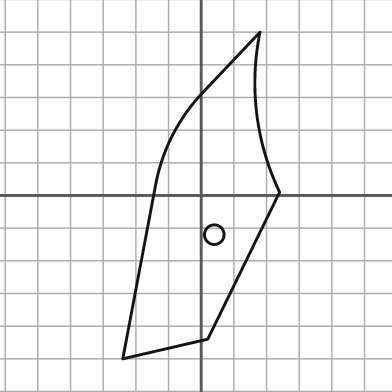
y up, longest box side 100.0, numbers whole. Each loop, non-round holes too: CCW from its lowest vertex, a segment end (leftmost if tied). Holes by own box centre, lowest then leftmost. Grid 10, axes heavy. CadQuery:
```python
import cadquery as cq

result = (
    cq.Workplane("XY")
    .moveTo(-24.0, -50.0)
    .lineTo(2.0, -44.0)
    .lineTo(24.0, 1.0)
    .threePointArc((17.0, 25.0), (18.0, 50.0))
    .lineTo(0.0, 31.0)
    .threePointArc((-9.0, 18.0), (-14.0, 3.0))
    .close()
    .moveTo(4.0, -12.0)
    .circle(3.0)
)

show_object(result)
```